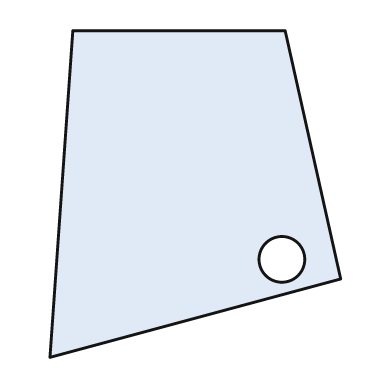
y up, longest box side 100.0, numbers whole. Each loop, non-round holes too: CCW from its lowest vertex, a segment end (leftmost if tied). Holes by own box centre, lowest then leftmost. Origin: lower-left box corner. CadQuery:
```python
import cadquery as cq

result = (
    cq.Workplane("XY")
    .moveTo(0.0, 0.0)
    .lineTo(89.0, 24.0)
    .lineTo(72.0, 100.0)
    .lineTo(7.0, 100.0)
    .close()
    .moveTo(71.0, 30.0)
    .circle(7.0)
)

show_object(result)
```